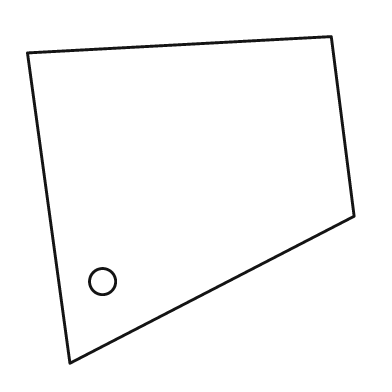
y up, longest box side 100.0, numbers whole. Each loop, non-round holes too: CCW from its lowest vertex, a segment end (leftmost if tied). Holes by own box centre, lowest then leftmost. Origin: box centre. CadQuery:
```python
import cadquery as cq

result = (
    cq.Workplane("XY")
    .moveTo(-37.0, -50.0)
    .lineTo(50.0, -5.0)
    .lineTo(43.0, 50.0)
    .lineTo(-50.0, 45.0)
    .close()
    .moveTo(-27.0, -25.0)
    .circle(4.0)
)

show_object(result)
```